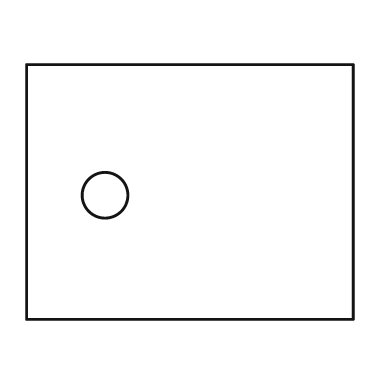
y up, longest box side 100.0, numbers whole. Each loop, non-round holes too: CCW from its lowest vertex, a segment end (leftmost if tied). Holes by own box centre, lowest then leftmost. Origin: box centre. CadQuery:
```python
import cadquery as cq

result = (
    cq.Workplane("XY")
    .moveTo(-50.0, -39.0)
    .lineTo(50.0, -39.0)
    .lineTo(50.0, 39.0)
    .lineTo(-50.0, 39.0)
    .close()
    .moveTo(-26.0, -1.0)
    .circle(7.0)
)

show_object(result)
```